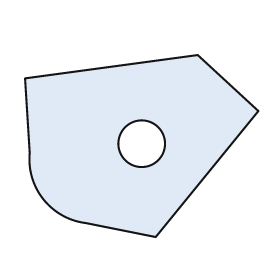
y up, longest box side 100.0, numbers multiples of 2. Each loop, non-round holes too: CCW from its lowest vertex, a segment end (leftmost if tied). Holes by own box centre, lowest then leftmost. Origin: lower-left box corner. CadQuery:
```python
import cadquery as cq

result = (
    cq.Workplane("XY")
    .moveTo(56.0, 0.0)
    .lineTo(100.0, 54.0)
    .lineTo(74.0, 78.0)
    .lineTo(0.0, 68.0)
    .lineTo(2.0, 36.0)
    .threePointArc((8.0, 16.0), (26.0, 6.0))
    .close()
    .moveTo(50.0, 40.0)
    .circle(10.0)
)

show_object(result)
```